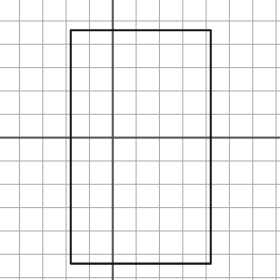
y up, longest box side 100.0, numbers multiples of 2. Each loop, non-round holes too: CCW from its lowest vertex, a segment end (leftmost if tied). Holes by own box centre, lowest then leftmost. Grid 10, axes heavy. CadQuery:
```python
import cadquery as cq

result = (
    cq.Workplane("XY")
    .moveTo(-18.0, -54.0)
    .lineTo(42.0, -54.0)
    .lineTo(42.0, 46.0)
    .lineTo(-18.0, 46.0)
    .close()
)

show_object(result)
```